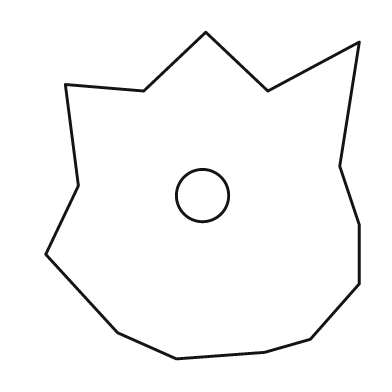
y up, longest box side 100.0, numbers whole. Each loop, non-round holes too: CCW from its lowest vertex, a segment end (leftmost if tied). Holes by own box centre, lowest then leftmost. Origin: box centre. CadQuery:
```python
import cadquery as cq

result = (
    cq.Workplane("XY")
    .moveTo(-8.0, -50.0)
    .lineTo(19.0, -48.0)
    .lineTo(33.0, -44.0)
    .lineTo(48.0, -27.0)
    .lineTo(48.0, -9.0)
    .lineTo(42.0, 9.0)
    .lineTo(48.0, 47.0)
    .lineTo(20.0, 32.0)
    .lineTo(1.0, 50.0)
    .lineTo(-18.0, 32.0)
    .lineTo(-42.0, 34.0)
    .lineTo(-38.0, 3.0)
    .lineTo(-48.0, -18.0)
    .lineTo(-26.0, -42.0)
    .close()
    .moveTo(0.0, 0.0)
    .circle(8.0)
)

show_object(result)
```